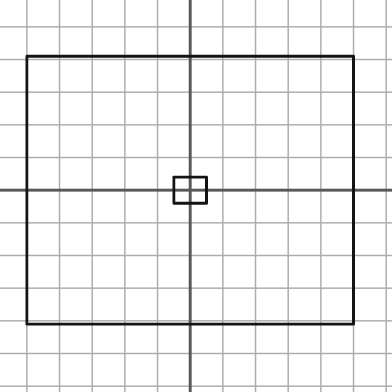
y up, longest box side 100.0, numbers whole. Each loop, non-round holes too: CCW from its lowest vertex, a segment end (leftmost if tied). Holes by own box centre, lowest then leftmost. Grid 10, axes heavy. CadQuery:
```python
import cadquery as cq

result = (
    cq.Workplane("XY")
    .moveTo(-50.0, -41.0)
    .lineTo(50.0, -41.0)
    .lineTo(50.0, 41.0)
    .lineTo(-50.0, 41.0)
    .close()
    .moveTo(-5.0, -4.0)
    .lineTo(5.0, -4.0)
    .lineTo(5.0, 4.0)
    .lineTo(-5.0, 4.0)
    .close()
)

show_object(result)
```